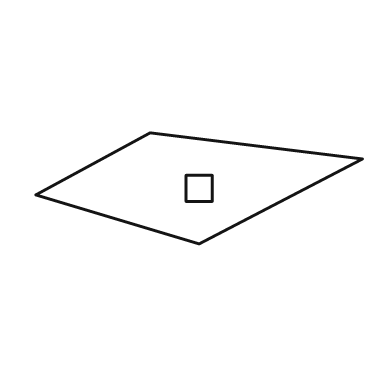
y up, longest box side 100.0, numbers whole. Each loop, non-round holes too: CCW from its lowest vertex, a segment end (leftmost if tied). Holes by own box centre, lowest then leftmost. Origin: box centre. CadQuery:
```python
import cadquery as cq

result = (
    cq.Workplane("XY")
    .moveTo(0.0, -17.0)
    .lineTo(50.0, 9.0)
    .lineTo(-15.0, 17.0)
    .lineTo(-50.0, -2.0)
    .close()
    .moveTo(-4.0, -4.0)
    .lineTo(4.0, -4.0)
    .lineTo(4.0, 4.0)
    .lineTo(-4.0, 4.0)
    .close()
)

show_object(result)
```